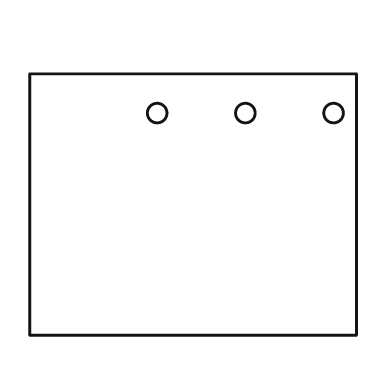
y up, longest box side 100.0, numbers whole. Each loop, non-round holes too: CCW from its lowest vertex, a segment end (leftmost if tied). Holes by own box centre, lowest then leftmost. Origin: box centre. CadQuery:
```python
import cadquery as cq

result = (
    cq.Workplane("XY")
    .moveTo(-50.0, -40.0)
    .lineTo(50.0, -40.0)
    .lineTo(50.0, 40.0)
    .lineTo(-50.0, 40.0)
    .close()
    .moveTo(-11.0, 28.0)
    .circle(3.0)
    .moveTo(16.0, 28.0)
    .circle(3.0)
    .moveTo(43.0, 28.0)
    .circle(3.0)
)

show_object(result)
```